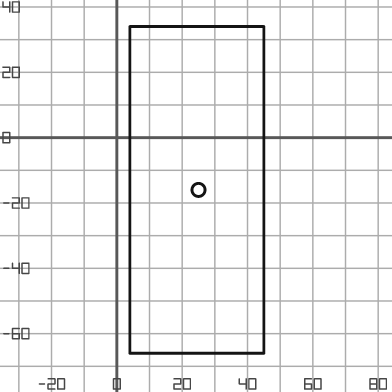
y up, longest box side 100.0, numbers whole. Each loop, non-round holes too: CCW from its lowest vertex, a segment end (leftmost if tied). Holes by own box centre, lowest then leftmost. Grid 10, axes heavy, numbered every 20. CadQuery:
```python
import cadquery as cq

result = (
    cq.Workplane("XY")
    .moveTo(4.0, -66.0)
    .lineTo(45.0, -66.0)
    .lineTo(45.0, 34.0)
    .lineTo(4.0, 34.0)
    .close()
    .moveTo(25.0, -16.0)
    .circle(2.0)
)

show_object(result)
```